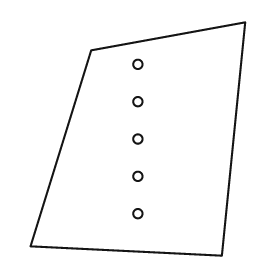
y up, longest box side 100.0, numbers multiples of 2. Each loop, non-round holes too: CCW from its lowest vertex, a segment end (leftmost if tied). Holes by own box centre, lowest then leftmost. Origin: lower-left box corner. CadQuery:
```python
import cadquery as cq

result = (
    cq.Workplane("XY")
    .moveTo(82.0, 0.0)
    .lineTo(92.0, 100.0)
    .lineTo(26.0, 88.0)
    .lineTo(0.0, 4.0)
    .close()
    .moveTo(46.0, 18.0)
    .circle(2.0)
    .moveTo(46.0, 34.0)
    .circle(2.0)
    .moveTo(46.0, 50.0)
    .circle(2.0)
    .moveTo(46.0, 66.0)
    .circle(2.0)
    .moveTo(46.0, 82.0)
    .circle(2.0)
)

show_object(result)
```